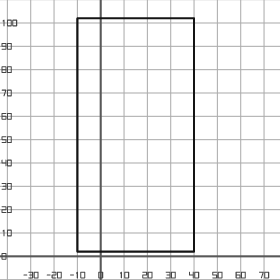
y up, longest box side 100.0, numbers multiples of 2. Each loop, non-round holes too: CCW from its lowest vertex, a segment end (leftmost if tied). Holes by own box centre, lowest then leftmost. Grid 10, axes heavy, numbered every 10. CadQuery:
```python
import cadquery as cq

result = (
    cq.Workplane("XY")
    .moveTo(-10.0, 2.0)
    .lineTo(40.0, 2.0)
    .lineTo(40.0, 102.0)
    .lineTo(-10.0, 102.0)
    .close()
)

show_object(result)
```